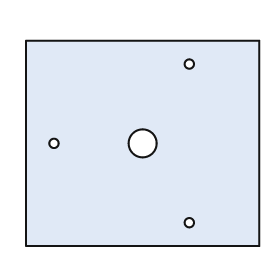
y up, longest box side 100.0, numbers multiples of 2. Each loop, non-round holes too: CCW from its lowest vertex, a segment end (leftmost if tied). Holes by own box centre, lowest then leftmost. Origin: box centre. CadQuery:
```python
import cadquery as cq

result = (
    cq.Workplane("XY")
    .moveTo(-50.0, -44.0)
    .lineTo(50.0, -44.0)
    .lineTo(50.0, 44.0)
    .lineTo(-50.0, 44.0)
    .close()
    .moveTo(20.0, -34.0)
    .circle(2.0)
    .moveTo(-38.0, 0.0)
    .circle(2.0)
    .moveTo(0.0, 0.0)
    .circle(6.0)
    .moveTo(20.0, 34.0)
    .circle(2.0)
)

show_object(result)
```